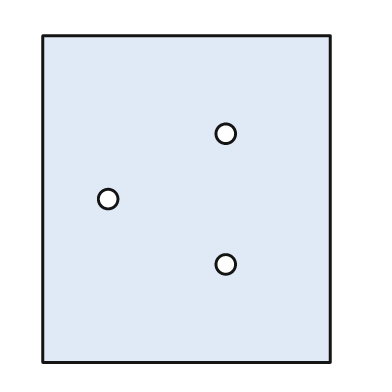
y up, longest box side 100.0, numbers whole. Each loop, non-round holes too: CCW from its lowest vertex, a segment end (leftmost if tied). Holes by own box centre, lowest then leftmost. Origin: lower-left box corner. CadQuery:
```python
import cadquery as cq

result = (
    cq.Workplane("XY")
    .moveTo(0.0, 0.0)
    .lineTo(88.0, 0.0)
    .lineTo(88.0, 100.0)
    .lineTo(0.0, 100.0)
    .close()
    .moveTo(56.0, 30.0)
    .circle(3.0)
    .moveTo(20.0, 50.0)
    .circle(3.0)
    .moveTo(56.0, 70.0)
    .circle(3.0)
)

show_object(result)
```